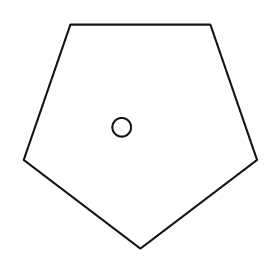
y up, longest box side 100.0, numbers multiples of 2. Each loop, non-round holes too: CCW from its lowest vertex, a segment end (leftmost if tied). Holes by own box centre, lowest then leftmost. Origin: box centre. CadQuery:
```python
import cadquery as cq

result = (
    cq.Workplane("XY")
    .moveTo(0.0, -48.0)
    .lineTo(50.0, -10.0)
    .lineTo(30.0, 48.0)
    .lineTo(-30.0, 48.0)
    .lineTo(-50.0, -10.0)
    .close()
    .moveTo(-8.0, 4.0)
    .circle(4.0)
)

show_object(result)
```